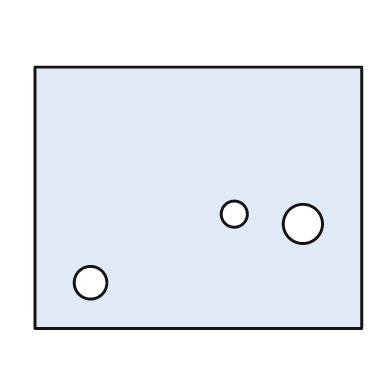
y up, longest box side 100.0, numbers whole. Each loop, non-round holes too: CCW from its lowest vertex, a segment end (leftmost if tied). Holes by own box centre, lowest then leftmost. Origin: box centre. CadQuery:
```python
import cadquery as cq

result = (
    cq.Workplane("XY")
    .moveTo(-50.0, -40.0)
    .lineTo(50.0, -40.0)
    .lineTo(50.0, 40.0)
    .lineTo(-50.0, 40.0)
    .close()
    .moveTo(-33.0, -26.0)
    .circle(5.0)
    .moveTo(32.0, -8.0)
    .circle(6.0)
    .moveTo(11.0, -5.0)
    .circle(4.0)
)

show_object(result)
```